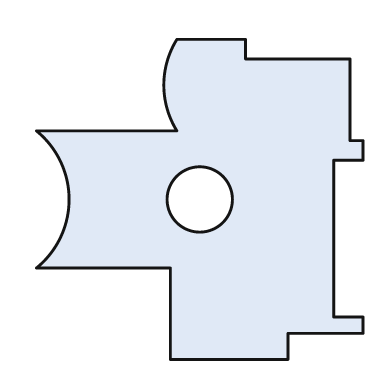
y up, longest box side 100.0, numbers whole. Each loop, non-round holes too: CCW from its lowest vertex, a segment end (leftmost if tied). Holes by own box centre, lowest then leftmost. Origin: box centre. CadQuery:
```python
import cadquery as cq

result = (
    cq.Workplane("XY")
    .moveTo(-9.0, -49.0)
    .lineTo(27.0, -49.0)
    .lineTo(27.0, -41.0)
    .lineTo(50.0, -41.0)
    .lineTo(50.0, -36.0)
    .lineTo(41.0, -36.0)
    .lineTo(41.0, 12.0)
    .lineTo(50.0, 12.0)
    .lineTo(50.0, 18.0)
    .lineTo(46.0, 18.0)
    .lineTo(46.0, 43.0)
    .lineTo(14.0, 43.0)
    .lineTo(14.0, 49.0)
    .lineTo(-7.0, 49.0)
    .threePointArc((-11.0, 35.0), (-7.0, 21.0))
    .lineTo(-50.0, 21.0)
    .threePointArc((-40.0, 0.0), (-50.0, -21.0))
    .lineTo(-9.0, -21.0)
    .close()
    .moveTo(0.0, 0.0)
    .circle(10.0)
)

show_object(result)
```